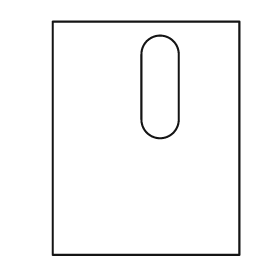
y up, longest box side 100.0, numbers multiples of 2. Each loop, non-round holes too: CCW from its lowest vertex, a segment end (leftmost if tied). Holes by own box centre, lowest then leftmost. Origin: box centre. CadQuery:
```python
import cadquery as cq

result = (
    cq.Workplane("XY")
    .moveTo(-40.0, -50.0)
    .lineTo(40.0, -50.0)
    .lineTo(40.0, 50.0)
    .lineTo(-40.0, 50.0)
    .close()
    .moveTo(-2.0, 8.0)
    .threePointArc((6.0, 0.0), (14.0, 8.0))
    .lineTo(14.0, 36.0)
    .threePointArc((6.0, 44.0), (-2.0, 36.0))
    .close()
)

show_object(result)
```